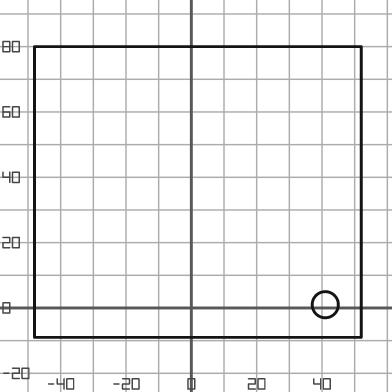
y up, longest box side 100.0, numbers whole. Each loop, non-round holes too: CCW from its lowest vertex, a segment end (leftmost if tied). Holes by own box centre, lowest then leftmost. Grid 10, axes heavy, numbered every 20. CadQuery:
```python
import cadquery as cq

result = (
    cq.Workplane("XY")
    .moveTo(-48.0, -9.0)
    .lineTo(52.0, -9.0)
    .lineTo(52.0, 80.0)
    .lineTo(-48.0, 80.0)
    .close()
    .moveTo(41.0, 1.0)
    .circle(4.0)
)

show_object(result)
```